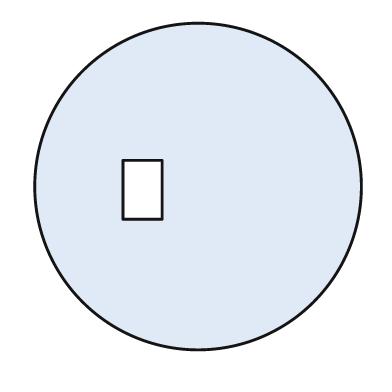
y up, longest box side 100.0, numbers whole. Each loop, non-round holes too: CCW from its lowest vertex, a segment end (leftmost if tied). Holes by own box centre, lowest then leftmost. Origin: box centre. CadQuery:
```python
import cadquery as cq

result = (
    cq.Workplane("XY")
    .moveTo(0.0, 0.0)
    .circle(50.0)
    .moveTo(-23.0, -10.0)
    .lineTo(-11.0, -10.0)
    .lineTo(-11.0, 8.0)
    .lineTo(-23.0, 8.0)
    .close()
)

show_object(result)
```